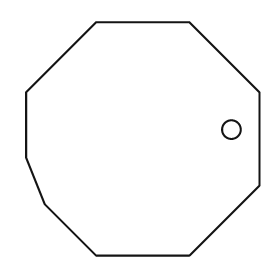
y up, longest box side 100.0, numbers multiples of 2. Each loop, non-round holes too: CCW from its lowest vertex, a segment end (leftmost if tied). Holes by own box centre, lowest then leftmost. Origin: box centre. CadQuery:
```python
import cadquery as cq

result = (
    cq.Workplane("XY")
    .moveTo(-20.0, -50.0)
    .lineTo(20.0, -50.0)
    .lineTo(50.0, -20.0)
    .lineTo(50.0, 20.0)
    .lineTo(20.0, 50.0)
    .lineTo(-20.0, 50.0)
    .lineTo(-50.0, 20.0)
    .lineTo(-50.0, -8.0)
    .lineTo(-42.0, -28.0)
    .close()
    .moveTo(38.0, 4.0)
    .circle(4.0)
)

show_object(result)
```